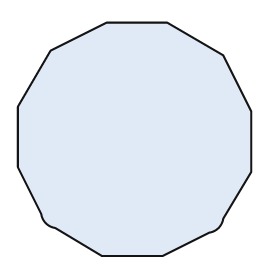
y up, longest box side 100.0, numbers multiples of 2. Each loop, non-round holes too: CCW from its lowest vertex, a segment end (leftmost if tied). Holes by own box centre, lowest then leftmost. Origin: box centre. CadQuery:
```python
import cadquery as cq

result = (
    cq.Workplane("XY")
    .moveTo(-14.0, -50.0)
    .lineTo(12.0, -50.0)
    .lineTo(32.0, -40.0)
    .threePointArc((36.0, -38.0), (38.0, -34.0))
    .lineTo(50.0, -14.0)
    .lineTo(50.0, 12.0)
    .lineTo(38.0, 36.0)
    .lineTo(14.0, 50.0)
    .lineTo(-12.0, 50.0)
    .lineTo(-36.0, 38.0)
    .lineTo(-50.0, 14.0)
    .lineTo(-50.0, -12.0)
    .lineTo(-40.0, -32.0)
    .threePointArc((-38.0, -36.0), (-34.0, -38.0))
    .close()
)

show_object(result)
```